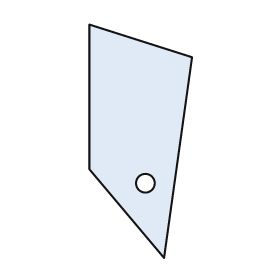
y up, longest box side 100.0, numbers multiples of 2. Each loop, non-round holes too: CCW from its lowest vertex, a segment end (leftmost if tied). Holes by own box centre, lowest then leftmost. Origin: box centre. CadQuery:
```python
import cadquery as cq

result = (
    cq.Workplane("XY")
    .moveTo(10.0, -50.0)
    .lineTo(22.0, 36.0)
    .lineTo(-22.0, 50.0)
    .lineTo(-22.0, -12.0)
    .close()
    .moveTo(2.0, -18.0)
    .circle(4.0)
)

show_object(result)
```